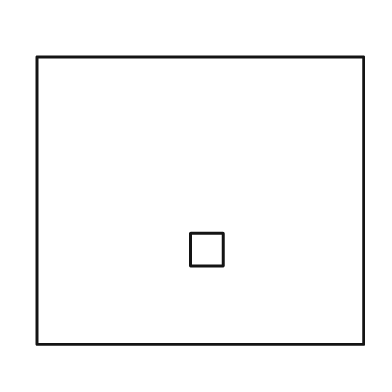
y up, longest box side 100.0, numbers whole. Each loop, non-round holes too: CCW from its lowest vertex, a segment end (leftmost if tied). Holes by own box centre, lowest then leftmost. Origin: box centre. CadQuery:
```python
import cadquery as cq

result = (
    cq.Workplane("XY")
    .moveTo(-50.0, -44.0)
    .lineTo(50.0, -44.0)
    .lineTo(50.0, 44.0)
    .lineTo(-50.0, 44.0)
    .close()
    .moveTo(-3.0, -20.0)
    .lineTo(7.0, -20.0)
    .lineTo(7.0, -10.0)
    .lineTo(-3.0, -10.0)
    .close()
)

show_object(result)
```